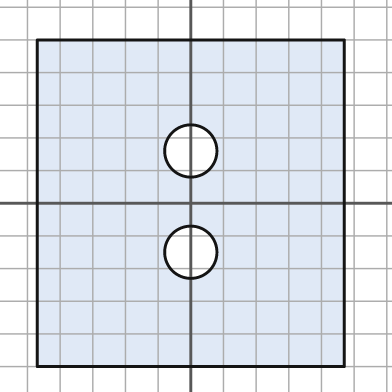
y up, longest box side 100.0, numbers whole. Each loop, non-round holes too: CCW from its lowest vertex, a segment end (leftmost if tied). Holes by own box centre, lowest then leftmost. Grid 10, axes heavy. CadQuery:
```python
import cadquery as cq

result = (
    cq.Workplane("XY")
    .moveTo(-47.0, -50.0)
    .lineTo(47.0, -50.0)
    .lineTo(47.0, 50.0)
    .lineTo(-47.0, 50.0)
    .close()
    .moveTo(0.0, -15.0)
    .circle(8.0)
    .moveTo(0.0, 16.0)
    .circle(8.0)
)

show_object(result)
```